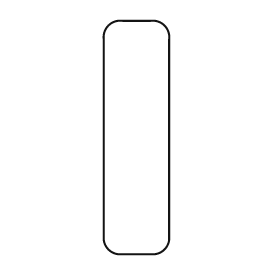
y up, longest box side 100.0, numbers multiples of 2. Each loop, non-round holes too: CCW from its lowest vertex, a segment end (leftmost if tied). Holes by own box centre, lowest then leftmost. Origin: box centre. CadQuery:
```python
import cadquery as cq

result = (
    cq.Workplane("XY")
    .moveTo(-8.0, -50.0)
    .lineTo(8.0, -50.0)
    .threePointArc((12.0, -48.0), (14.0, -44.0))
    .lineTo(14.0, 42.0)
    .threePointArc((12.0, 48.0), (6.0, 50.0))
    .lineTo(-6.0, 50.0)
    .threePointArc((-12.0, 48.0), (-14.0, 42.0))
    .lineTo(-14.0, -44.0)
    .threePointArc((-12.0, -48.0), (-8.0, -50.0))
    .close()
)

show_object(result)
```